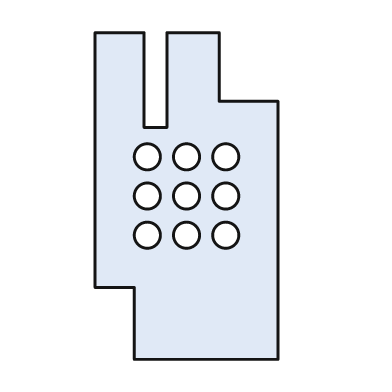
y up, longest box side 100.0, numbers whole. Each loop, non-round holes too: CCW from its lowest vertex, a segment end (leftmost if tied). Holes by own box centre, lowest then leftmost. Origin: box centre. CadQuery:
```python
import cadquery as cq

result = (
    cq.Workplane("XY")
    .moveTo(-16.0, -50.0)
    .lineTo(28.0, -50.0)
    .lineTo(28.0, 29.0)
    .lineTo(10.0, 29.0)
    .lineTo(10.0, 50.0)
    .lineTo(-6.0, 50.0)
    .lineTo(-6.0, 21.0)
    .lineTo(-13.0, 21.0)
    .lineTo(-13.0, 50.0)
    .lineTo(-28.0, 50.0)
    .lineTo(-28.0, -28.0)
    .lineTo(-16.0, -28.0)
    .close()
    .moveTo(-12.0, -12.0)
    .circle(4.0)
    .moveTo(0.0, -12.0)
    .circle(4.0)
    .moveTo(12.0, -12.0)
    .circle(4.0)
    .moveTo(-12.0, 0.0)
    .circle(4.0)
    .moveTo(0.0, 0.0)
    .circle(4.0)
    .moveTo(12.0, 0.0)
    .circle(4.0)
    .moveTo(-12.0, 12.0)
    .circle(4.0)
    .moveTo(0.0, 12.0)
    .circle(4.0)
    .moveTo(12.0, 12.0)
    .circle(4.0)
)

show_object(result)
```